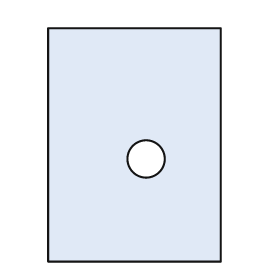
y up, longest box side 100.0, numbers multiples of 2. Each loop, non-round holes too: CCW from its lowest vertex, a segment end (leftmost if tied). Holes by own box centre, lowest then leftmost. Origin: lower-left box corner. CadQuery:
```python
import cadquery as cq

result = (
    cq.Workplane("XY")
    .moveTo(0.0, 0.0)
    .lineTo(74.0, 0.0)
    .lineTo(74.0, 100.0)
    .lineTo(0.0, 100.0)
    .close()
    .moveTo(42.0, 44.0)
    .circle(8.0)
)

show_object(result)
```